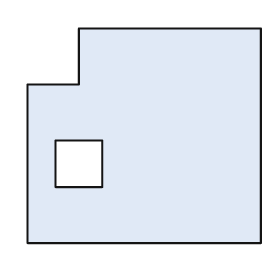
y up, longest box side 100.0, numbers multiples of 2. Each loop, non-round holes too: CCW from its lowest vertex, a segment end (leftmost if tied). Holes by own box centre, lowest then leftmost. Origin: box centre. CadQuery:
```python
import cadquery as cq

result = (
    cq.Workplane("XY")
    .moveTo(-50.0, -46.0)
    .lineTo(50.0, -46.0)
    .lineTo(50.0, 46.0)
    .lineTo(-28.0, 46.0)
    .lineTo(-28.0, 22.0)
    .lineTo(-50.0, 22.0)
    .close()
    .moveTo(-38.0, -22.0)
    .lineTo(-18.0, -22.0)
    .lineTo(-18.0, -2.0)
    .lineTo(-38.0, -2.0)
    .close()
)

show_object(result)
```